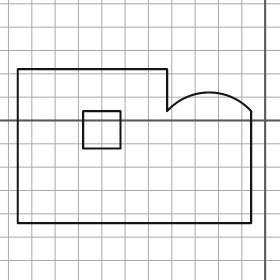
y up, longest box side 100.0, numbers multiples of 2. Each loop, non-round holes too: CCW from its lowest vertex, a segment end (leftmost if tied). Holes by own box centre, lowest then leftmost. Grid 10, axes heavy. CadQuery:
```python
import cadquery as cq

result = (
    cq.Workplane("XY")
    .moveTo(-106.0, -44.0)
    .lineTo(-6.0, -44.0)
    .lineTo(-6.0, 4.0)
    .threePointArc((-24.0, 12.0), (-42.0, 4.0))
    .lineTo(-42.0, 22.0)
    .lineTo(-106.0, 22.0)
    .close()
    .moveTo(-78.0, -12.0)
    .lineTo(-62.0, -12.0)
    .lineTo(-62.0, 4.0)
    .lineTo(-78.0, 4.0)
    .close()
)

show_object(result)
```